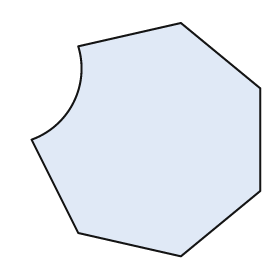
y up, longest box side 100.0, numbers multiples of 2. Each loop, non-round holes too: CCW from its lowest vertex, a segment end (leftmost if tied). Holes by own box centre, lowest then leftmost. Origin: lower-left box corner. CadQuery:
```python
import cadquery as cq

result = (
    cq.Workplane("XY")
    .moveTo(64.0, 0.0)
    .lineTo(98.0, 28.0)
    .lineTo(98.0, 72.0)
    .lineTo(64.0, 100.0)
    .lineTo(20.0, 90.0)
    .threePointArc((18.0, 66.0), (0.0, 50.0))
    .lineTo(20.0, 10.0)
    .close()
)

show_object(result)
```